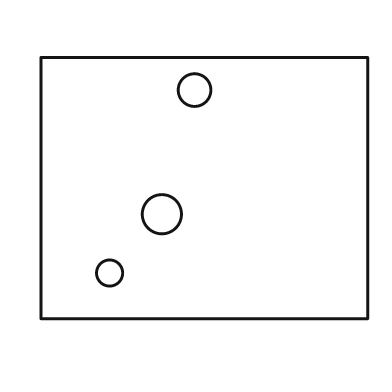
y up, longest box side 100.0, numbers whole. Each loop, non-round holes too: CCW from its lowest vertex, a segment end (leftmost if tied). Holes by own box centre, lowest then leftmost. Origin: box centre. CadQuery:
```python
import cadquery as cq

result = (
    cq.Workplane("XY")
    .moveTo(-50.0, -40.0)
    .lineTo(50.0, -40.0)
    .lineTo(50.0, 40.0)
    .lineTo(-50.0, 40.0)
    .close()
    .moveTo(-29.0, -26.0)
    .circle(4.0)
    .moveTo(-13.0, -8.0)
    .circle(6.0)
    .moveTo(-3.0, 30.0)
    .circle(5.0)
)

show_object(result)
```